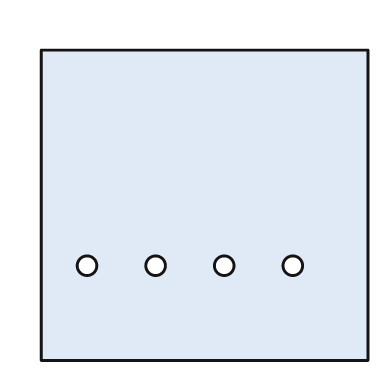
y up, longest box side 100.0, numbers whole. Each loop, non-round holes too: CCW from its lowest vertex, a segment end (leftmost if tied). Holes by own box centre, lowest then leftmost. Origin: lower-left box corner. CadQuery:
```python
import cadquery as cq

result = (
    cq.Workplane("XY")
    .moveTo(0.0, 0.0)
    .lineTo(100.0, 0.0)
    .lineTo(100.0, 95.0)
    .lineTo(0.0, 95.0)
    .close()
    .moveTo(14.0, 29.0)
    .circle(3.0)
    .moveTo(35.0, 29.0)
    .circle(3.0)
    .moveTo(56.0, 29.0)
    .circle(3.0)
    .moveTo(77.0, 29.0)
    .circle(3.0)
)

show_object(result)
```